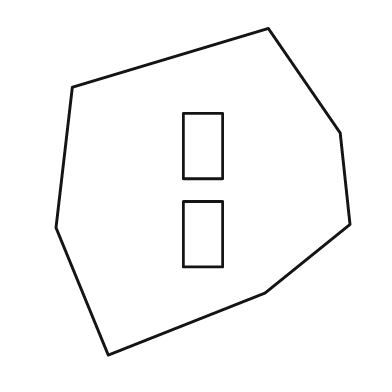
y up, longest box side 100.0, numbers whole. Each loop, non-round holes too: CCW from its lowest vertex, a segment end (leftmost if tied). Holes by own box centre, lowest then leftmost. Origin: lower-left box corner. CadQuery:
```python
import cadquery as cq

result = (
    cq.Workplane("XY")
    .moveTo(16.0, 0.0)
    .lineTo(64.0, 19.0)
    .lineTo(90.0, 40.0)
    .lineTo(87.0, 68.0)
    .lineTo(65.0, 100.0)
    .lineTo(5.0, 82.0)
    .lineTo(0.0, 39.0)
    .close()
    .moveTo(39.0, 27.0)
    .lineTo(51.0, 27.0)
    .lineTo(51.0, 47.0)
    .lineTo(39.0, 47.0)
    .close()
    .moveTo(39.0, 54.0)
    .lineTo(51.0, 54.0)
    .lineTo(51.0, 74.0)
    .lineTo(39.0, 74.0)
    .close()
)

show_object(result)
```